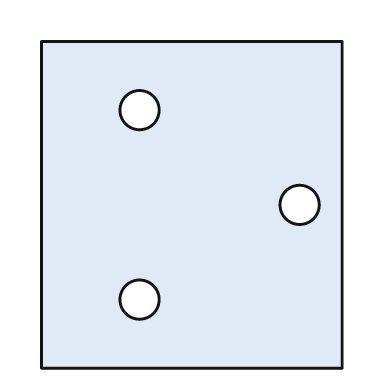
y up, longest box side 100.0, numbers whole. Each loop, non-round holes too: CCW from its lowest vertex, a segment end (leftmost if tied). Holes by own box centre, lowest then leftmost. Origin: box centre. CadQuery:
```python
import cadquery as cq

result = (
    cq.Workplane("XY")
    .moveTo(-46.0, -50.0)
    .lineTo(46.0, -50.0)
    .lineTo(46.0, 50.0)
    .lineTo(-46.0, 50.0)
    .close()
    .moveTo(-16.0, -29.0)
    .circle(6.0)
    .moveTo(33.0, 0.0)
    .circle(6.0)
    .moveTo(-16.0, 29.0)
    .circle(6.0)
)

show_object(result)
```